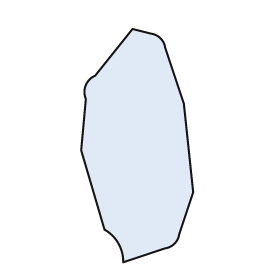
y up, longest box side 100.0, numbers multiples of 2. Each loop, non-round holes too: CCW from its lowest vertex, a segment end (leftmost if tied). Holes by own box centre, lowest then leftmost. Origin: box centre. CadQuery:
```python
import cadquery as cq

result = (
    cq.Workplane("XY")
    .moveTo(-6.0, -50.0)
    .lineTo(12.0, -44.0)
    .threePointArc((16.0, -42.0), (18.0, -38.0))
    .lineTo(24.0, -20.0)
    .lineTo(20.0, 18.0)
    .lineTo(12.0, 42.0)
    .threePointArc((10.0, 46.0), (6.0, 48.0))
    .lineTo(-2.0, 50.0)
    .lineTo(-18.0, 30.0)
    .threePointArc((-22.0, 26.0), (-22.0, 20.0))
    .lineTo(-24.0, -2.0)
    .lineTo(-14.0, -36.0)
    .threePointArc((-8.0, -42.0), (-6.0, -50.0))
    .close()
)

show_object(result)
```